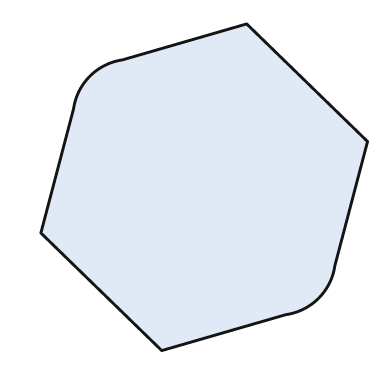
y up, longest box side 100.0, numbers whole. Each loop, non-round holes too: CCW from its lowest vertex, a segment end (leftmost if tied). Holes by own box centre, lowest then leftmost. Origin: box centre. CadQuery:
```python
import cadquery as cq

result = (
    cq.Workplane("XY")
    .moveTo(-13.0, -50.0)
    .lineTo(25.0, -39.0)
    .threePointArc((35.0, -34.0), (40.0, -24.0))
    .lineTo(50.0, 14.0)
    .lineTo(13.0, 50.0)
    .lineTo(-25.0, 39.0)
    .threePointArc((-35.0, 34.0), (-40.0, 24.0))
    .lineTo(-50.0, -14.0)
    .close()
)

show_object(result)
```